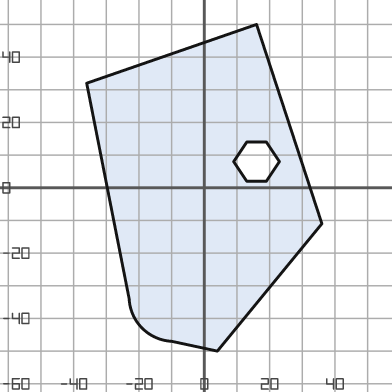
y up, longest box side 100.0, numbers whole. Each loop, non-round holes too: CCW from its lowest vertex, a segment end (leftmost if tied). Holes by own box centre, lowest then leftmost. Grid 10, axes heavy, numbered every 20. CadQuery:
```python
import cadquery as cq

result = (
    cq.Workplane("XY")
    .moveTo(4.0, -50.0)
    .lineTo(36.0, -11.0)
    .lineTo(16.0, 50.0)
    .lineTo(-36.0, 32.0)
    .lineTo(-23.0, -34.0)
    .threePointArc((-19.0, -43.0), (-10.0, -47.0))
    .close()
    .moveTo(13.0, 2.0)
    .lineTo(19.0, 2.0)
    .lineTo(23.0, 8.0)
    .lineTo(19.0, 14.0)
    .lineTo(13.0, 14.0)
    .lineTo(9.0, 8.0)
    .close()
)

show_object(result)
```